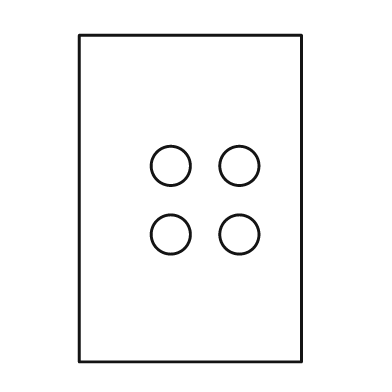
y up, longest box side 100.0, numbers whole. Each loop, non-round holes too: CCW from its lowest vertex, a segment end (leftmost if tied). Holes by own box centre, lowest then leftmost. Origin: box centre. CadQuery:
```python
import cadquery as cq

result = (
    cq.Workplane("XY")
    .moveTo(-34.0, -50.0)
    .lineTo(34.0, -50.0)
    .lineTo(34.0, 50.0)
    .lineTo(-34.0, 50.0)
    .close()
    .moveTo(-6.0, -11.0)
    .circle(6.0)
    .moveTo(15.0, -11.0)
    .circle(6.0)
    .moveTo(-6.0, 10.0)
    .circle(6.0)
    .moveTo(15.0, 10.0)
    .circle(6.0)
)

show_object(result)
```